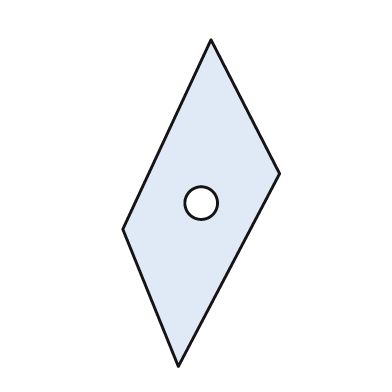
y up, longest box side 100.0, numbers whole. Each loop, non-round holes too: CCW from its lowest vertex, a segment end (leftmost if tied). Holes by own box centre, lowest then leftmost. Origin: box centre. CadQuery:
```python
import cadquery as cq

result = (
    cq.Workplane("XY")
    .moveTo(-7.0, -50.0)
    .lineTo(24.0, 9.0)
    .lineTo(3.0, 50.0)
    .lineTo(-24.0, -8.0)
    .close()
    .moveTo(0.0, 0.0)
    .circle(5.0)
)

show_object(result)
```